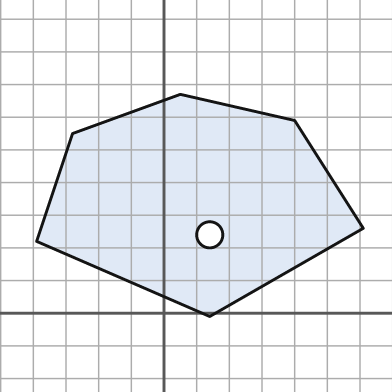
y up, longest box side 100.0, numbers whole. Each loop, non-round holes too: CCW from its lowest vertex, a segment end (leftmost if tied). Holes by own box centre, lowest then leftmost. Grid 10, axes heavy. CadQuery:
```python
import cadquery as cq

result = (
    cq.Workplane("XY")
    .moveTo(14.0, -1.0)
    .lineTo(61.0, 26.0)
    .lineTo(40.0, 59.0)
    .lineTo(5.0, 67.0)
    .lineTo(-28.0, 55.0)
    .lineTo(-39.0, 22.0)
    .close()
    .moveTo(14.0, 24.0)
    .circle(4.0)
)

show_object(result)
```